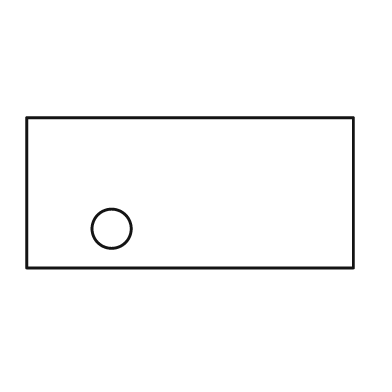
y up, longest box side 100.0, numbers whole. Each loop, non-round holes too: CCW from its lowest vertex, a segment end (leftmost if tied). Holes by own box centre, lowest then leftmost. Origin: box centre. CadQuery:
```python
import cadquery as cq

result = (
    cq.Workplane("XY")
    .moveTo(-50.0, -23.0)
    .lineTo(50.0, -23.0)
    .lineTo(50.0, 23.0)
    .lineTo(-50.0, 23.0)
    .close()
    .moveTo(-24.0, -11.0)
    .circle(6.0)
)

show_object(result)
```